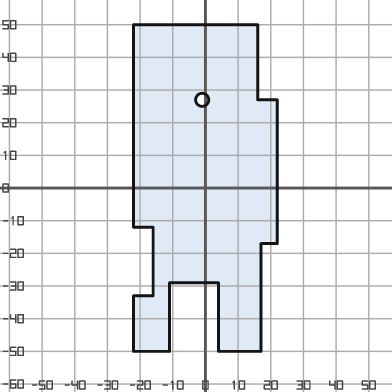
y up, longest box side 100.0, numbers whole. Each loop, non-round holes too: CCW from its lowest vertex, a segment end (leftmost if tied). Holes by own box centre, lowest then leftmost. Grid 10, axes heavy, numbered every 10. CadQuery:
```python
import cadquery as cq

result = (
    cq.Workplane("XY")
    .moveTo(-22.0, -50.0)
    .lineTo(-11.0, -50.0)
    .lineTo(-11.0, -29.0)
    .lineTo(4.0, -29.0)
    .lineTo(4.0, -50.0)
    .lineTo(17.0, -50.0)
    .lineTo(17.0, -17.0)
    .lineTo(22.0, -17.0)
    .lineTo(22.0, 27.0)
    .lineTo(16.0, 27.0)
    .lineTo(16.0, 50.0)
    .lineTo(-22.0, 50.0)
    .lineTo(-22.0, -12.0)
    .lineTo(-16.0, -12.0)
    .lineTo(-16.0, -33.0)
    .lineTo(-22.0, -33.0)
    .close()
    .moveTo(-1.0, 27.0)
    .circle(2.0)
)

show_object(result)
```